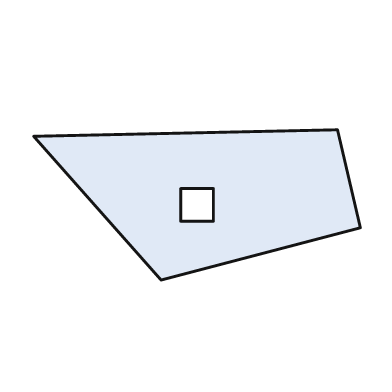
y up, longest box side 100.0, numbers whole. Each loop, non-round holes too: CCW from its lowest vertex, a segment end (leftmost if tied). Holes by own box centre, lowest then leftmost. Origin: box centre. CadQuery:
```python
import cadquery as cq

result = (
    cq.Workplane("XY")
    .moveTo(-11.0, -23.0)
    .lineTo(50.0, -7.0)
    .lineTo(43.0, 23.0)
    .lineTo(-50.0, 21.0)
    .close()
    .moveTo(-5.0, -5.0)
    .lineTo(5.0, -5.0)
    .lineTo(5.0, 5.0)
    .lineTo(-5.0, 5.0)
    .close()
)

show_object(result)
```